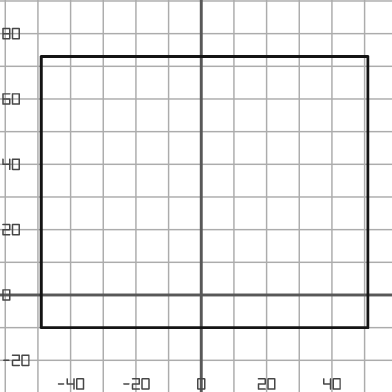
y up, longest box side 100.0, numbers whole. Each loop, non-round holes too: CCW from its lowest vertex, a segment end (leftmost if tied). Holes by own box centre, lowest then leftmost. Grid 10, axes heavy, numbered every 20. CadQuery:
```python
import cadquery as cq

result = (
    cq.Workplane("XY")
    .moveTo(-49.0, -10.0)
    .lineTo(51.0, -10.0)
    .lineTo(51.0, 73.0)
    .lineTo(-49.0, 73.0)
    .close()
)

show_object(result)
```